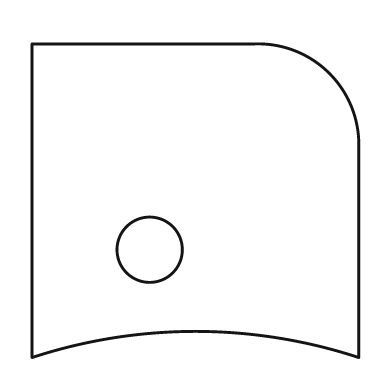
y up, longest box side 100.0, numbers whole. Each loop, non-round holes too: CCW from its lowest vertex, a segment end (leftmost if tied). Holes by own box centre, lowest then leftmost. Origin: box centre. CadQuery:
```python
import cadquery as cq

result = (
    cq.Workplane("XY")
    .moveTo(-50.0, -48.0)
    .threePointArc((0.0, -40.0), (50.0, -48.0))
    .lineTo(50.0, 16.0)
    .threePointArc((41.0, 39.0), (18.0, 48.0))
    .lineTo(-50.0, 48.0)
    .close()
    .moveTo(-14.0, -15.0)
    .circle(10.0)
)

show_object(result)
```